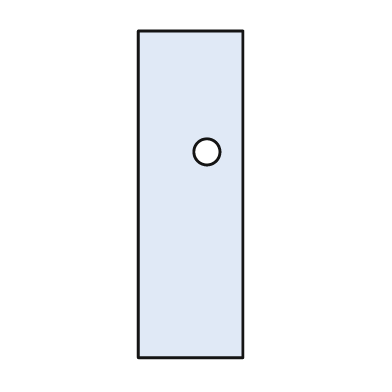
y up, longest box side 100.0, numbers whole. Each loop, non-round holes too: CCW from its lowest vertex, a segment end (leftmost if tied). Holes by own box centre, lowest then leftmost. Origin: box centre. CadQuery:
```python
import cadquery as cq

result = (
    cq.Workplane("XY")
    .moveTo(-16.0, -50.0)
    .lineTo(16.0, -50.0)
    .lineTo(16.0, 50.0)
    .lineTo(-16.0, 50.0)
    .close()
    .moveTo(5.0, 13.0)
    .circle(4.0)
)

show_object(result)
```